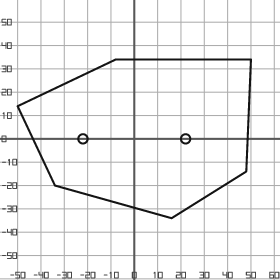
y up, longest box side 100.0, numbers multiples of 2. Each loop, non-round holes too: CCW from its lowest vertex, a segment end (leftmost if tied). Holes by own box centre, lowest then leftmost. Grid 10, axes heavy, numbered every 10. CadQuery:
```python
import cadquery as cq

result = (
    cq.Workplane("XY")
    .moveTo(16.0, -34.0)
    .lineTo(48.0, -14.0)
    .lineTo(50.0, 34.0)
    .lineTo(-8.0, 34.0)
    .lineTo(-50.0, 14.0)
    .lineTo(-34.0, -20.0)
    .close()
    .moveTo(-22.0, 0.0)
    .circle(2.0)
    .moveTo(22.0, 0.0)
    .circle(2.0)
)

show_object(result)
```